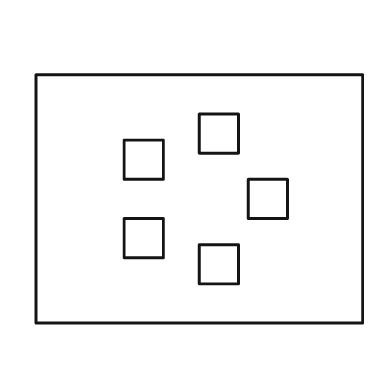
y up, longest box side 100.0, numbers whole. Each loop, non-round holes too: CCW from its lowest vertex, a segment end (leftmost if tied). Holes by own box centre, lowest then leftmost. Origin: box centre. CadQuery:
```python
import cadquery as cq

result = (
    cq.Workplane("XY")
    .moveTo(-50.0, -38.0)
    .lineTo(50.0, -38.0)
    .lineTo(50.0, 38.0)
    .lineTo(-50.0, 38.0)
    .close()
    .moveTo(0.0, -26.0)
    .lineTo(12.0, -26.0)
    .lineTo(12.0, -14.0)
    .lineTo(0.0, -14.0)
    .close()
    .moveTo(-23.0, -18.0)
    .lineTo(-11.0, -18.0)
    .lineTo(-11.0, -6.0)
    .lineTo(-23.0, -6.0)
    .close()
    .moveTo(15.0, -6.0)
    .lineTo(27.0, -6.0)
    .lineTo(27.0, 6.0)
    .lineTo(15.0, 6.0)
    .close()
    .moveTo(-23.0, 6.0)
    .lineTo(-11.0, 6.0)
    .lineTo(-11.0, 18.0)
    .lineTo(-23.0, 18.0)
    .close()
    .moveTo(0.0, 14.0)
    .lineTo(12.0, 14.0)
    .lineTo(12.0, 26.0)
    .lineTo(0.0, 26.0)
    .close()
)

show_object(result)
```